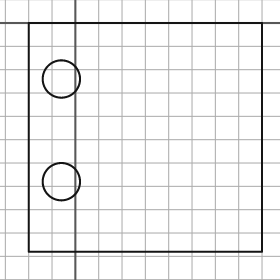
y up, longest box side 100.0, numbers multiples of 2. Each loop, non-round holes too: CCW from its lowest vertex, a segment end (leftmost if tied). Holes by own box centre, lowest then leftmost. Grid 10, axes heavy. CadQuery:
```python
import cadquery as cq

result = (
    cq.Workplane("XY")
    .moveTo(-20.0, -98.0)
    .lineTo(80.0, -98.0)
    .lineTo(80.0, 0.0)
    .lineTo(-20.0, 0.0)
    .close()
    .moveTo(-6.0, -68.0)
    .circle(8.0)
    .moveTo(-6.0, -24.0)
    .circle(8.0)
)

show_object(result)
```